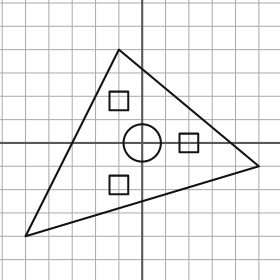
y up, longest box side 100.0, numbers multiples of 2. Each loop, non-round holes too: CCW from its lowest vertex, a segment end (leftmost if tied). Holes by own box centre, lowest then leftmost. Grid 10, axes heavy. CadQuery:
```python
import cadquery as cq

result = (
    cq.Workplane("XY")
    .moveTo(-50.0, -40.0)
    .lineTo(50.0, -10.0)
    .lineTo(-10.0, 40.0)
    .close()
    .moveTo(-14.0, -22.0)
    .lineTo(-6.0, -22.0)
    .lineTo(-6.0, -14.0)
    .lineTo(-14.0, -14.0)
    .close()
    .moveTo(0.0, 0.0)
    .circle(8.0)
    .moveTo(16.0, -4.0)
    .lineTo(24.0, -4.0)
    .lineTo(24.0, 4.0)
    .lineTo(16.0, 4.0)
    .close()
    .moveTo(-14.0, 14.0)
    .lineTo(-6.0, 14.0)
    .lineTo(-6.0, 22.0)
    .lineTo(-14.0, 22.0)
    .close()
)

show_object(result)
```